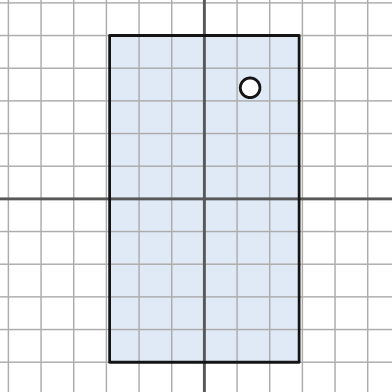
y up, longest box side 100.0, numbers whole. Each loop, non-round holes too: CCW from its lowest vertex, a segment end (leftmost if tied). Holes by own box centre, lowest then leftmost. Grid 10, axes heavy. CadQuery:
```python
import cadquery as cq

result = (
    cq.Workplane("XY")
    .moveTo(-29.0, -50.0)
    .lineTo(29.0, -50.0)
    .lineTo(29.0, 50.0)
    .lineTo(-29.0, 50.0)
    .close()
    .moveTo(14.0, 34.0)
    .circle(3.0)
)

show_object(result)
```